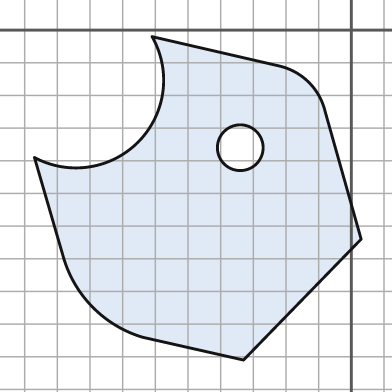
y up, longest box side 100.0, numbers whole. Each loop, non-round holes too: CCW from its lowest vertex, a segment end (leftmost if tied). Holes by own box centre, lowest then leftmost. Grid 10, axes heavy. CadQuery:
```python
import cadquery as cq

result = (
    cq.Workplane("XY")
    .moveTo(-33.0, -101.0)
    .lineTo(3.0, -64.0)
    .lineTo(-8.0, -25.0)
    .threePointArc((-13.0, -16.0), (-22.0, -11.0))
    .lineTo(-61.0, -2.0)
    .threePointArc((-65.0, -34.0), (-97.0, -39.0))
    .lineTo(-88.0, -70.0)
    .threePointArc((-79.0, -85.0), (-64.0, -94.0))
    .close()
    .moveTo(-34.0, -36.0)
    .circle(7.0)
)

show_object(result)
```